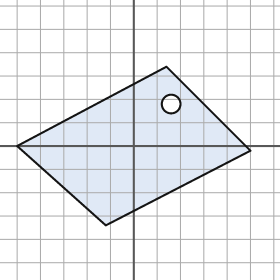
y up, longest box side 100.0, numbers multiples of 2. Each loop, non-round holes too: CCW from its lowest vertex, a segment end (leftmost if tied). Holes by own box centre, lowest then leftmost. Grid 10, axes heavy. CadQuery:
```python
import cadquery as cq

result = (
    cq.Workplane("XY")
    .moveTo(-12.0, -34.0)
    .lineTo(50.0, -2.0)
    .lineTo(14.0, 34.0)
    .lineTo(-50.0, 0.0)
    .close()
    .moveTo(16.0, 18.0)
    .circle(4.0)
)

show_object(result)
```